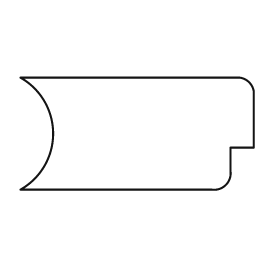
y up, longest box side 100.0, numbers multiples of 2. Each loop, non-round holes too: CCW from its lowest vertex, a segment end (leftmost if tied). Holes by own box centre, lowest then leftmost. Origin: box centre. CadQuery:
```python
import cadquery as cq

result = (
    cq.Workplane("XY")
    .moveTo(-50.0, -24.0)
    .lineTo(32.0, -24.0)
    .threePointArc((38.0, -22.0), (40.0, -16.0))
    .lineTo(40.0, -6.0)
    .lineTo(50.0, -6.0)
    .lineTo(50.0, 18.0)
    .threePointArc((48.0, 22.0), (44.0, 24.0))
    .lineTo(-50.0, 24.0)
    .threePointArc((-36.0, 0.0), (-50.0, -24.0))
    .close()
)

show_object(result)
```